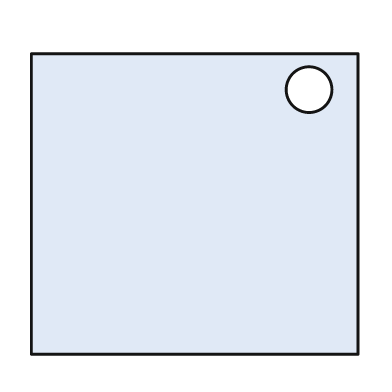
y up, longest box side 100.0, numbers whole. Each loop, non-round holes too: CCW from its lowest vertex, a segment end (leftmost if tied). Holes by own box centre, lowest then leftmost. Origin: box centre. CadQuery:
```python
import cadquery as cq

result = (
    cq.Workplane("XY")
    .moveTo(-50.0, -46.0)
    .lineTo(50.0, -46.0)
    .lineTo(50.0, 46.0)
    .lineTo(-50.0, 46.0)
    .close()
    .moveTo(35.0, 35.0)
    .circle(7.0)
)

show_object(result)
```